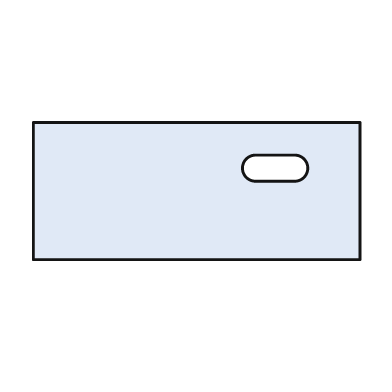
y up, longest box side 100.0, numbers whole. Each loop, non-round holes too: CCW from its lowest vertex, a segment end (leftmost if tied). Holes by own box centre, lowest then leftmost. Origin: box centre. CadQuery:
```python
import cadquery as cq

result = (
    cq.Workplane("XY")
    .moveTo(-50.0, -21.0)
    .lineTo(50.0, -21.0)
    .lineTo(50.0, 21.0)
    .lineTo(-50.0, 21.0)
    .close()
    .moveTo(18.0, 3.0)
    .lineTo(30.0, 3.0)
    .threePointArc((34.0, 7.0), (30.0, 11.0))
    .lineTo(18.0, 11.0)
    .threePointArc((14.0, 7.0), (18.0, 3.0))
    .close()
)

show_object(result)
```